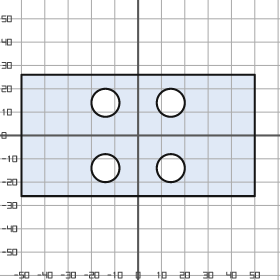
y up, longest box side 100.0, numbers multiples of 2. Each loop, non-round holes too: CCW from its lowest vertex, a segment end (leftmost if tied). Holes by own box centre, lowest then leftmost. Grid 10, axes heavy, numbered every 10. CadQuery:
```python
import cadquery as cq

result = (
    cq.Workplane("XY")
    .moveTo(-50.0, -26.0)
    .lineTo(50.0, -26.0)
    .lineTo(50.0, 26.0)
    .lineTo(-50.0, 26.0)
    .close()
    .moveTo(-14.0, -14.0)
    .circle(6.0)
    .moveTo(14.0, -14.0)
    .circle(6.0)
    .moveTo(-14.0, 14.0)
    .circle(6.0)
    .moveTo(14.0, 14.0)
    .circle(6.0)
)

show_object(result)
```